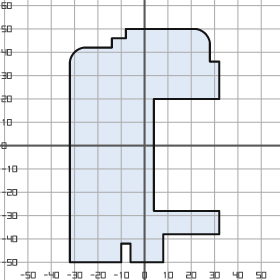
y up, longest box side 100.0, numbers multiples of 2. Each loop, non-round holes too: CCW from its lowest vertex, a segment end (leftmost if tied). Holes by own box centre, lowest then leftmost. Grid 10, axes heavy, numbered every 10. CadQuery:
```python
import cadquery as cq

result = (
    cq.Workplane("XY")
    .moveTo(-32.0, -50.0)
    .lineTo(-10.0, -50.0)
    .lineTo(-10.0, -42.0)
    .lineTo(-6.0, -42.0)
    .lineTo(-6.0, -50.0)
    .lineTo(8.0, -50.0)
    .lineTo(8.0, -38.0)
    .lineTo(32.0, -38.0)
    .lineTo(32.0, -28.0)
    .lineTo(4.0, -28.0)
    .lineTo(4.0, 20.0)
    .lineTo(32.0, 20.0)
    .lineTo(32.0, 36.0)
    .lineTo(28.0, 36.0)
    .lineTo(28.0, 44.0)
    .threePointArc((26.0, 48.0), (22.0, 50.0))
    .lineTo(-8.0, 50.0)
    .lineTo(-8.0, 46.0)
    .lineTo(-14.0, 46.0)
    .lineTo(-14.0, 42.0)
    .lineTo(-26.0, 42.0)
    .threePointArc((-30.0, 40.0), (-32.0, 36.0))
    .close()
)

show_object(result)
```